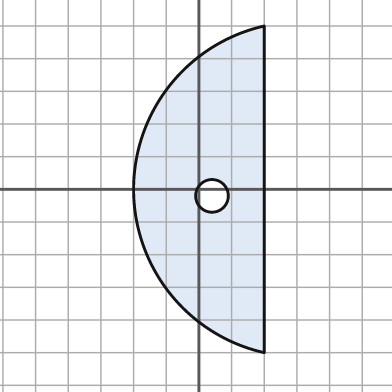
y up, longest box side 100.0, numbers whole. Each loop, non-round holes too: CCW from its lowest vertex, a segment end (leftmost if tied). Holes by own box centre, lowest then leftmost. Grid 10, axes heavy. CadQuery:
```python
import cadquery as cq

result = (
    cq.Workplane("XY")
    .moveTo(20.0, -50.0)
    .lineTo(20.0, 50.0)
    .threePointArc((-20.0, 0.0), (20.0, -50.0))
    .close()
    .moveTo(4.0, -2.0)
    .circle(5.0)
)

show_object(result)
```